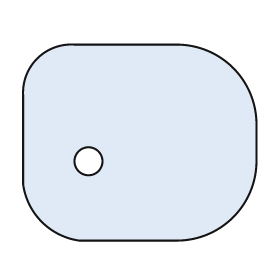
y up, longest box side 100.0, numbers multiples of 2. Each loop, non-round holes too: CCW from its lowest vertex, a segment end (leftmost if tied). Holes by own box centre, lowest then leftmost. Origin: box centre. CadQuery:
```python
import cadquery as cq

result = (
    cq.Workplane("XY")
    .moveTo(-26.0, -42.0)
    .lineTo(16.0, -42.0)
    .threePointArc((40.0, -32.0), (50.0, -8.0))
    .lineTo(50.0, 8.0)
    .threePointArc((40.0, 32.0), (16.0, 42.0))
    .lineTo(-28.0, 42.0)
    .threePointArc((-44.0, 36.0), (-50.0, 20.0))
    .lineTo(-50.0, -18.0)
    .threePointArc((-42.0, -34.0), (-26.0, -42.0))
    .close()
    .moveTo(-22.0, -8.0)
    .circle(6.0)
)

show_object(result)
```